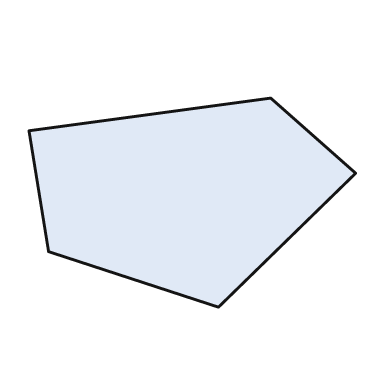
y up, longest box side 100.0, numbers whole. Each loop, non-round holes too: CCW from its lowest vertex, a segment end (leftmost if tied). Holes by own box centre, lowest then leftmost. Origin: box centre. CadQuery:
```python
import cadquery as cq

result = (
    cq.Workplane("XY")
    .moveTo(8.0, -32.0)
    .lineTo(50.0, 9.0)
    .lineTo(24.0, 32.0)
    .lineTo(-50.0, 22.0)
    .lineTo(-44.0, -15.0)
    .close()
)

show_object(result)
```